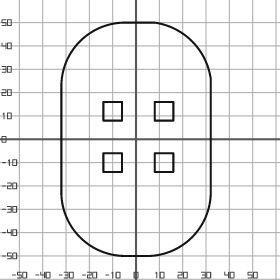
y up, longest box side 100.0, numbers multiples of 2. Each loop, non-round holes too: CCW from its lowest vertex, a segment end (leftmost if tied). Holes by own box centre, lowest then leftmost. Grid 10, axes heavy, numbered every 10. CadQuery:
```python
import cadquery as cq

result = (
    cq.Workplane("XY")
    .moveTo(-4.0, -50.0)
    .lineTo(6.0, -50.0)
    .threePointArc((24.0, -42.0), (32.0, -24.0))
    .lineTo(32.0, 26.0)
    .threePointArc((24.0, 42.0), (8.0, 50.0))
    .lineTo(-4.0, 50.0)
    .threePointArc((-24.0, 42.0), (-32.0, 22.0))
    .lineTo(-32.0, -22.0)
    .threePointArc((-24.0, -42.0), (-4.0, -50.0))
    .close()
    .moveTo(-14.0, -14.0)
    .lineTo(-6.0, -14.0)
    .lineTo(-6.0, -6.0)
    .lineTo(-14.0, -6.0)
    .close()
    .moveTo(8.0, -14.0)
    .lineTo(16.0, -14.0)
    .lineTo(16.0, -6.0)
    .lineTo(8.0, -6.0)
    .close()
    .moveTo(-14.0, 8.0)
    .lineTo(-6.0, 8.0)
    .lineTo(-6.0, 16.0)
    .lineTo(-14.0, 16.0)
    .close()
    .moveTo(8.0, 8.0)
    .lineTo(16.0, 8.0)
    .lineTo(16.0, 16.0)
    .lineTo(8.0, 16.0)
    .close()
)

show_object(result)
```